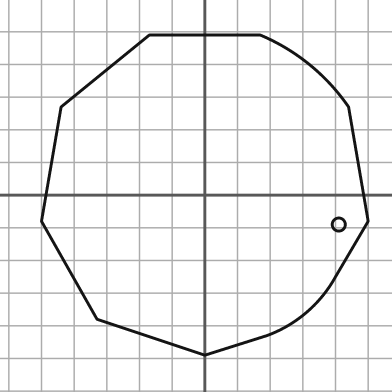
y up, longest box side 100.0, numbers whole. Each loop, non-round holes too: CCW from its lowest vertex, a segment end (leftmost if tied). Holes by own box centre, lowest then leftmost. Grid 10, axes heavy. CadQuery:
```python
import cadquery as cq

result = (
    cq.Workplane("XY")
    .moveTo(0.0, -49.0)
    .lineTo(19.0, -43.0)
    .threePointArc((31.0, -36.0), (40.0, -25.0))
    .lineTo(50.0, -8.0)
    .lineTo(44.0, 27.0)
    .threePointArc((32.0, 40.0), (17.0, 49.0))
    .lineTo(-17.0, 49.0)
    .lineTo(-44.0, 27.0)
    .lineTo(-50.0, -8.0)
    .lineTo(-33.0, -38.0)
    .close()
    .moveTo(41.0, -9.0)
    .circle(2.0)
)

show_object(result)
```